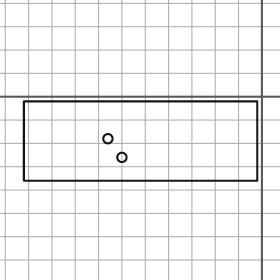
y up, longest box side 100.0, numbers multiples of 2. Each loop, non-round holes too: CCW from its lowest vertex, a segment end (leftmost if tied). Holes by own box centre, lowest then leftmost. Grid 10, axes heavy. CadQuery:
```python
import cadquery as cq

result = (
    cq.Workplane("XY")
    .moveTo(-102.0, -36.0)
    .lineTo(-2.0, -36.0)
    .lineTo(-2.0, -2.0)
    .lineTo(-102.0, -2.0)
    .close()
    .moveTo(-60.0, -26.0)
    .circle(2.0)
    .moveTo(-66.0, -18.0)
    .circle(2.0)
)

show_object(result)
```